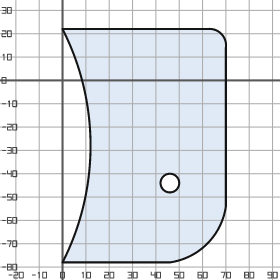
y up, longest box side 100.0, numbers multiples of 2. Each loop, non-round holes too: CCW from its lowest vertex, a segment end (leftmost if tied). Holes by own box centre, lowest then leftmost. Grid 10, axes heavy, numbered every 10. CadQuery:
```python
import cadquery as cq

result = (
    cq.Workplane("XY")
    .moveTo(0.0, -78.0)
    .lineTo(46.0, -78.0)
    .threePointArc((62.0, -70.0), (70.0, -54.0))
    .lineTo(70.0, 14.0)
    .threePointArc((68.0, 20.0), (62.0, 22.0))
    .lineTo(0.0, 22.0)
    .threePointArc((12.0, -28.0), (0.0, -78.0))
    .close()
    .moveTo(46.0, -44.0)
    .circle(4.0)
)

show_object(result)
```